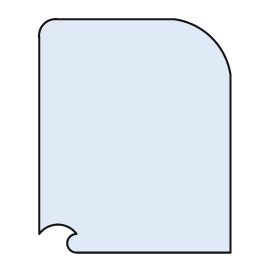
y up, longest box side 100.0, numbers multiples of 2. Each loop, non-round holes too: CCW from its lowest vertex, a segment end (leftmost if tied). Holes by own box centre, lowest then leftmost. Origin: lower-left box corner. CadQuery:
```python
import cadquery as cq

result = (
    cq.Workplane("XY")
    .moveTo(16.0, 0.0)
    .lineTo(82.0, 0.0)
    .lineTo(82.0, 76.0)
    .threePointArc((74.0, 92.0), (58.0, 100.0))
    .lineTo(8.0, 100.0)
    .threePointArc((2.0, 98.0), (0.0, 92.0))
    .lineTo(0.0, 8.0)
    .threePointArc((8.0, 12.0), (16.0, 8.0))
    .threePointArc((12.0, 4.0), (16.0, 0.0))
    .close()
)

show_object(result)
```